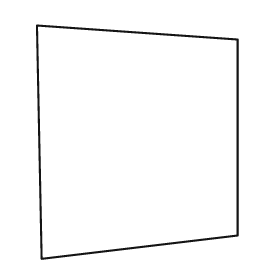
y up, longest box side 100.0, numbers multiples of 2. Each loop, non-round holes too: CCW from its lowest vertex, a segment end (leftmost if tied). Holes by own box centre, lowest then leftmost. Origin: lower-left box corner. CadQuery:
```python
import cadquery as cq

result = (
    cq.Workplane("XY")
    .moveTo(2.0, 0.0)
    .lineTo(86.0, 10.0)
    .lineTo(86.0, 94.0)
    .lineTo(0.0, 100.0)
    .close()
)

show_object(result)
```